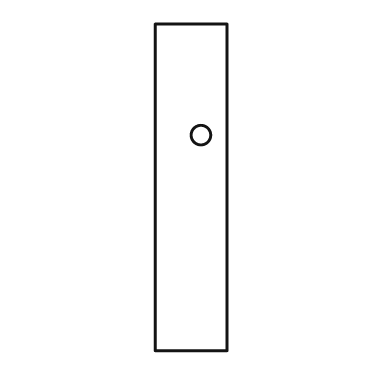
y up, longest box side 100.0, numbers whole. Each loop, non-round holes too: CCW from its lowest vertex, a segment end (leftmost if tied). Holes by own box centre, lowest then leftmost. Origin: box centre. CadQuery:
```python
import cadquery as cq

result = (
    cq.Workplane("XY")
    .moveTo(-11.0, -50.0)
    .lineTo(11.0, -50.0)
    .lineTo(11.0, 50.0)
    .lineTo(-11.0, 50.0)
    .close()
    .moveTo(3.0, 16.0)
    .circle(3.0)
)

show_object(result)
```